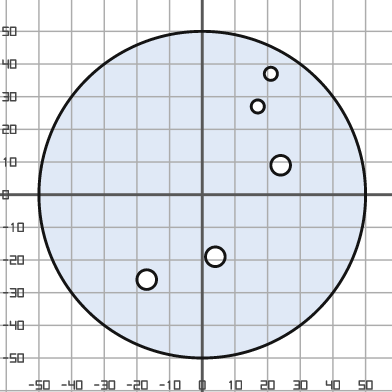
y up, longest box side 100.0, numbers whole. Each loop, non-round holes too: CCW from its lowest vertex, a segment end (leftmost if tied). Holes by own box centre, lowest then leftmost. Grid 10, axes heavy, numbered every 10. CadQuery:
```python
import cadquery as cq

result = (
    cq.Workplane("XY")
    .moveTo(0.0, 0.0)
    .circle(50.0)
    .moveTo(-17.0, -26.0)
    .circle(3.0)
    .moveTo(4.0, -19.0)
    .circle(3.0)
    .moveTo(24.0, 9.0)
    .circle(3.0)
    .moveTo(17.0, 27.0)
    .circle(2.0)
    .moveTo(21.0, 37.0)
    .circle(2.0)
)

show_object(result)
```